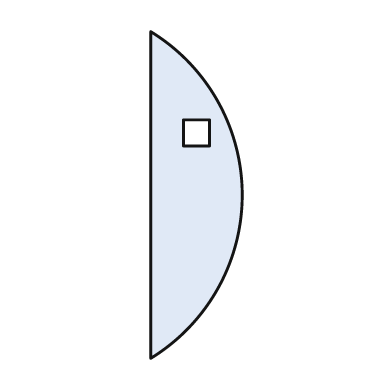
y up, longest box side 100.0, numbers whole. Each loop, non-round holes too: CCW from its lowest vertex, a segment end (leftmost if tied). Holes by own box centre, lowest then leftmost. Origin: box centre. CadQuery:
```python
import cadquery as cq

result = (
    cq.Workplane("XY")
    .moveTo(-14.0, -50.0)
    .threePointArc((14.0, 0.0), (-14.0, 50.0))
    .close()
    .moveTo(-4.0, 15.0)
    .lineTo(4.0, 15.0)
    .lineTo(4.0, 23.0)
    .lineTo(-4.0, 23.0)
    .close()
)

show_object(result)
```